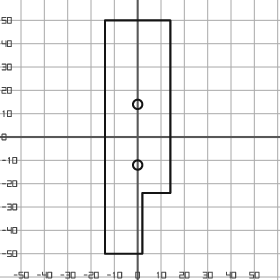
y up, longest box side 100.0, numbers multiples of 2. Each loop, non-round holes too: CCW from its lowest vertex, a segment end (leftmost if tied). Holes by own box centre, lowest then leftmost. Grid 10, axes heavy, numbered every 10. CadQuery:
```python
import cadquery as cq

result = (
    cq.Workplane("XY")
    .moveTo(-14.0, -50.0)
    .lineTo(2.0, -50.0)
    .lineTo(2.0, -24.0)
    .lineTo(14.0, -24.0)
    .lineTo(14.0, 50.0)
    .lineTo(-14.0, 50.0)
    .close()
    .moveTo(0.0, -12.0)
    .circle(2.0)
    .moveTo(0.0, 14.0)
    .circle(2.0)
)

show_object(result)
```